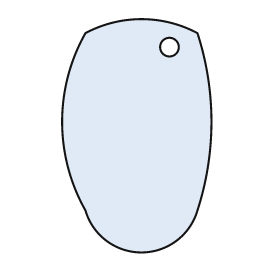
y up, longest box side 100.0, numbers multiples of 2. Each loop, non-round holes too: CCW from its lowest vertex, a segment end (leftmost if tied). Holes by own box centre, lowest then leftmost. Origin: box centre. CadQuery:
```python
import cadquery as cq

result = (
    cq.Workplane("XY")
    .moveTo(-22.0, -32.0)
    .threePointArc((2.0, -50.0), (26.0, -32.0))
    .threePointArc((32.0, 6.0), (26.0, 44.0))
    .threePointArc((2.0, 50.0), (-22.0, 44.0))
    .threePointArc((-32.0, 6.0), (-22.0, -32.0))
    .close()
    .moveTo(14.0, 38.0)
    .circle(4.0)
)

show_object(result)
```